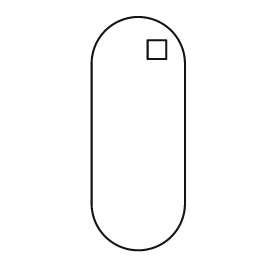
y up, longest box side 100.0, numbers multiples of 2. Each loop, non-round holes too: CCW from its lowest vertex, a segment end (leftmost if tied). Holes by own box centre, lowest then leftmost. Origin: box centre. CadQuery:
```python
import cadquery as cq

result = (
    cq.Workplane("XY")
    .moveTo(-20.0, -30.0)
    .threePointArc((0.0, -50.0), (20.0, -30.0))
    .lineTo(20.0, 30.0)
    .threePointArc((0.0, 50.0), (-20.0, 30.0))
    .close()
    .moveTo(4.0, 32.0)
    .lineTo(12.0, 32.0)
    .lineTo(12.0, 40.0)
    .lineTo(4.0, 40.0)
    .close()
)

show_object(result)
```